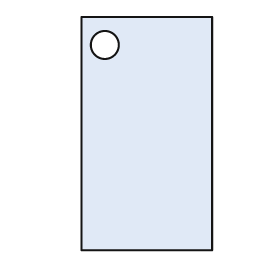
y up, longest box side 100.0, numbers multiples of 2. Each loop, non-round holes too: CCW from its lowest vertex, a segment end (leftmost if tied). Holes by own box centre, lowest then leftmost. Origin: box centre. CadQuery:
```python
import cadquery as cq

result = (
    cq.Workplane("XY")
    .moveTo(-28.0, -50.0)
    .lineTo(28.0, -50.0)
    .lineTo(28.0, 50.0)
    .lineTo(-28.0, 50.0)
    .close()
    .moveTo(-18.0, 38.0)
    .circle(6.0)
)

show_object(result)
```